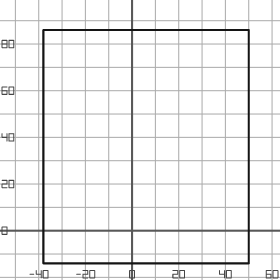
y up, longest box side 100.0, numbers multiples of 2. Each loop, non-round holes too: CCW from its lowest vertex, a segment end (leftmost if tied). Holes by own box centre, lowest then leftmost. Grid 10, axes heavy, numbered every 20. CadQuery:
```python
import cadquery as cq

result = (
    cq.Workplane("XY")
    .moveTo(-38.0, -14.0)
    .lineTo(50.0, -14.0)
    .lineTo(50.0, 86.0)
    .lineTo(-38.0, 86.0)
    .close()
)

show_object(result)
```